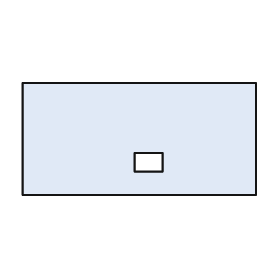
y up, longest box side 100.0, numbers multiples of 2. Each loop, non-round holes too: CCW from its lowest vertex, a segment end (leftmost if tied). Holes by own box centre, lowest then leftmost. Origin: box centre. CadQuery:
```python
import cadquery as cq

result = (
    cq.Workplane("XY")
    .moveTo(-50.0, -24.0)
    .lineTo(50.0, -24.0)
    .lineTo(50.0, 24.0)
    .lineTo(-50.0, 24.0)
    .close()
    .moveTo(-2.0, -14.0)
    .lineTo(10.0, -14.0)
    .lineTo(10.0, -6.0)
    .lineTo(-2.0, -6.0)
    .close()
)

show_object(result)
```